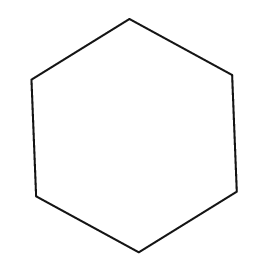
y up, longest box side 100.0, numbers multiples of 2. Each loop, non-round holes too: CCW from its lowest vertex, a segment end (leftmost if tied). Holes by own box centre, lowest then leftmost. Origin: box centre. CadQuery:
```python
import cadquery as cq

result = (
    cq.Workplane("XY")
    .moveTo(2.0, -50.0)
    .lineTo(44.0, -24.0)
    .lineTo(42.0, 26.0)
    .lineTo(-2.0, 50.0)
    .lineTo(-44.0, 24.0)
    .lineTo(-42.0, -26.0)
    .close()
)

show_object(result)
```